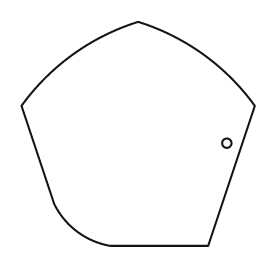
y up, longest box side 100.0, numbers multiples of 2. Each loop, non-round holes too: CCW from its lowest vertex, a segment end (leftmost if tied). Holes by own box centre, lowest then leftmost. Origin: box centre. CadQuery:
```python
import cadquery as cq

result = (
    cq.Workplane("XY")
    .moveTo(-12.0, -48.0)
    .lineTo(30.0, -48.0)
    .lineTo(50.0, 12.0)
    .threePointArc((28.0, 34.0), (0.0, 48.0))
    .threePointArc((-28.0, 34.0), (-50.0, 12.0))
    .lineTo(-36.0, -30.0)
    .threePointArc((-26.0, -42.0), (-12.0, -48.0))
    .close()
    .moveTo(38.0, -4.0)
    .circle(2.0)
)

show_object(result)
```